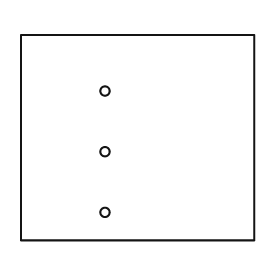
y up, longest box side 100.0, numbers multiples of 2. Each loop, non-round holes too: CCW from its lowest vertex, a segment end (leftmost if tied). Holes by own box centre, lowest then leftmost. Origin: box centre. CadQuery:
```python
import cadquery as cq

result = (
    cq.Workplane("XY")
    .moveTo(-50.0, -44.0)
    .lineTo(50.0, -44.0)
    .lineTo(50.0, 44.0)
    .lineTo(-50.0, 44.0)
    .close()
    .moveTo(-14.0, -32.0)
    .circle(2.0)
    .moveTo(-14.0, -6.0)
    .circle(2.0)
    .moveTo(-14.0, 20.0)
    .circle(2.0)
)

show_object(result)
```